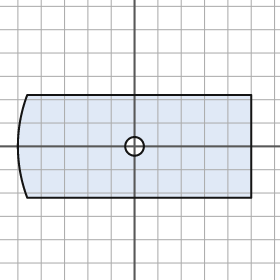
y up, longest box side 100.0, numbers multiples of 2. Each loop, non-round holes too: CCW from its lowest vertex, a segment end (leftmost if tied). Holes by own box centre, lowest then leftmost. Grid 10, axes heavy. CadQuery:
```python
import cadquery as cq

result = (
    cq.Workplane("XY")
    .moveTo(-46.0, -22.0)
    .lineTo(50.0, -22.0)
    .lineTo(50.0, 22.0)
    .lineTo(-46.0, 22.0)
    .threePointArc((-50.0, 0.0), (-46.0, -22.0))
    .close()
    .moveTo(0.0, 0.0)
    .circle(4.0)
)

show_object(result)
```